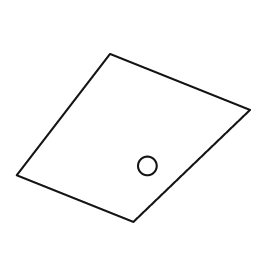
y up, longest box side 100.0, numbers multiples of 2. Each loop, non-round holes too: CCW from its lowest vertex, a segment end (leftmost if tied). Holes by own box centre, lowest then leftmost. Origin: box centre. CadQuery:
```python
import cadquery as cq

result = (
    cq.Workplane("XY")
    .moveTo(0.0, -36.0)
    .lineTo(50.0, 12.0)
    .lineTo(-10.0, 36.0)
    .lineTo(-50.0, -16.0)
    .close()
    .moveTo(6.0, -12.0)
    .circle(4.0)
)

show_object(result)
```